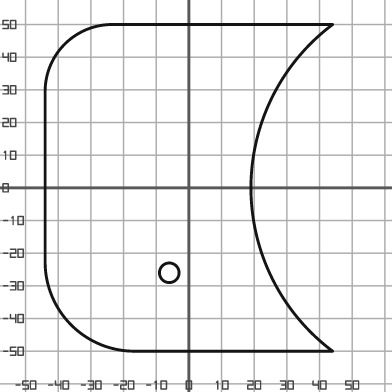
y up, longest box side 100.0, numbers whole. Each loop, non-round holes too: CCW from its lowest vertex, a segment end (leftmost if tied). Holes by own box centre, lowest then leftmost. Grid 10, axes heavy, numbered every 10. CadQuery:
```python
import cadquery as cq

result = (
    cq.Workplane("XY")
    .moveTo(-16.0, -50.0)
    .lineTo(44.0, -50.0)
    .threePointArc((19.0, 0.0), (44.0, 50.0))
    .lineTo(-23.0, 50.0)
    .threePointArc((-38.0, 44.0), (-44.0, 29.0))
    .lineTo(-44.0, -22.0)
    .threePointArc((-36.0, -42.0), (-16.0, -50.0))
    .close()
    .moveTo(-6.0, -26.0)
    .circle(3.0)
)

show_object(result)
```